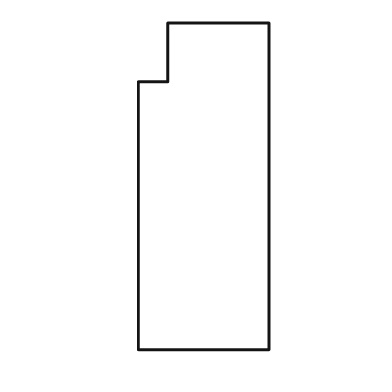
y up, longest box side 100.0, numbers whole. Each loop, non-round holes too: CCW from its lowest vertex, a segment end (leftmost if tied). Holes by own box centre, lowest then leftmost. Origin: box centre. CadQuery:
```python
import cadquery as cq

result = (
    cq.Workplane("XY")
    .moveTo(-20.0, -50.0)
    .lineTo(20.0, -50.0)
    .lineTo(20.0, 50.0)
    .lineTo(-11.0, 50.0)
    .lineTo(-11.0, 32.0)
    .lineTo(-20.0, 32.0)
    .close()
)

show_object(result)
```